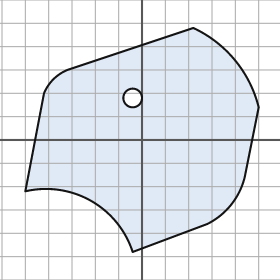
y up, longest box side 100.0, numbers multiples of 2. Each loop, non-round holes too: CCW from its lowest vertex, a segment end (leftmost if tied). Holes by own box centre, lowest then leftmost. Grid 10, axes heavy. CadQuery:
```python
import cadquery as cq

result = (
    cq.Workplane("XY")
    .moveTo(-4.0, -48.0)
    .lineTo(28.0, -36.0)
    .threePointArc((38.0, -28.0), (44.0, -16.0))
    .lineTo(50.0, 14.0)
    .threePointArc((40.0, 34.0), (22.0, 48.0))
    .lineTo(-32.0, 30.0)
    .threePointArc((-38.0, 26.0), (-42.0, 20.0))
    .lineTo(-50.0, -22.0)
    .threePointArc((-22.0, -26.0), (-4.0, -48.0))
    .close()
    .moveTo(-4.0, 18.0)
    .circle(4.0)
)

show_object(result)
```